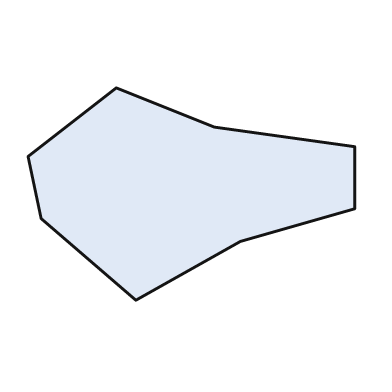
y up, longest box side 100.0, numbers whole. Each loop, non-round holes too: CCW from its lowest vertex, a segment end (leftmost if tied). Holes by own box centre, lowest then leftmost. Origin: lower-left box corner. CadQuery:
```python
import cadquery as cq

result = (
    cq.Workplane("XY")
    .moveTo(33.0, 0.0)
    .lineTo(65.0, 18.0)
    .lineTo(100.0, 28.0)
    .lineTo(100.0, 47.0)
    .lineTo(57.0, 53.0)
    .lineTo(27.0, 65.0)
    .lineTo(0.0, 44.0)
    .lineTo(4.0, 25.0)
    .close()
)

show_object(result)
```